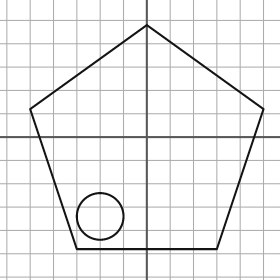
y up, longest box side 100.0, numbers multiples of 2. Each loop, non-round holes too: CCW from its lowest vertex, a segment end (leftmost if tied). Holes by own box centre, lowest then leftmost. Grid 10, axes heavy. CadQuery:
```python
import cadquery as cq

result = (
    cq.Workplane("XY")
    .moveTo(-30.0, -48.0)
    .lineTo(30.0, -48.0)
    .lineTo(50.0, 12.0)
    .lineTo(0.0, 48.0)
    .lineTo(-50.0, 12.0)
    .close()
    .moveTo(-20.0, -34.0)
    .circle(10.0)
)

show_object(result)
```